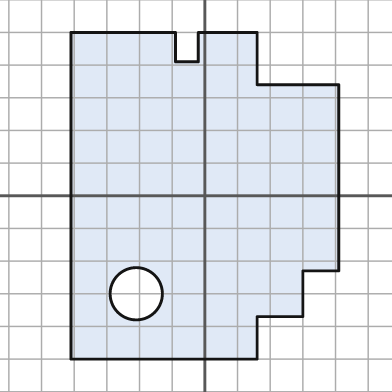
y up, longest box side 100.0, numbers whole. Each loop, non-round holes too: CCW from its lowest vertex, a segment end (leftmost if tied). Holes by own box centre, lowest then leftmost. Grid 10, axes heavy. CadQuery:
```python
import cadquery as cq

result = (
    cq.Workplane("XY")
    .moveTo(-41.0, -50.0)
    .lineTo(16.0, -50.0)
    .lineTo(16.0, -37.0)
    .lineTo(30.0, -37.0)
    .lineTo(30.0, -23.0)
    .lineTo(41.0, -23.0)
    .lineTo(41.0, 34.0)
    .lineTo(16.0, 34.0)
    .lineTo(16.0, 50.0)
    .lineTo(-2.0, 50.0)
    .lineTo(-2.0, 41.0)
    .lineTo(-9.0, 41.0)
    .lineTo(-9.0, 50.0)
    .lineTo(-41.0, 50.0)
    .close()
    .moveTo(-21.0, -30.0)
    .circle(8.0)
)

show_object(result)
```